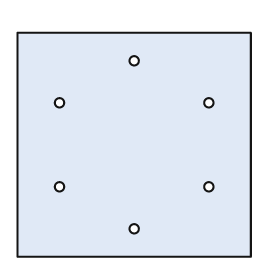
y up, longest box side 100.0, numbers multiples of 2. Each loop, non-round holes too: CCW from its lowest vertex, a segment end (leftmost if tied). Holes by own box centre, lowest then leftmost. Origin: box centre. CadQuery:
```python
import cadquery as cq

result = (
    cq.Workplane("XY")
    .moveTo(-50.0, -48.0)
    .lineTo(50.0, -48.0)
    .lineTo(50.0, 48.0)
    .lineTo(-50.0, 48.0)
    .close()
    .moveTo(0.0, -36.0)
    .circle(2.0)
    .moveTo(-32.0, -18.0)
    .circle(2.0)
    .moveTo(32.0, -18.0)
    .circle(2.0)
    .moveTo(-32.0, 18.0)
    .circle(2.0)
    .moveTo(32.0, 18.0)
    .circle(2.0)
    .moveTo(0.0, 36.0)
    .circle(2.0)
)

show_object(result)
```